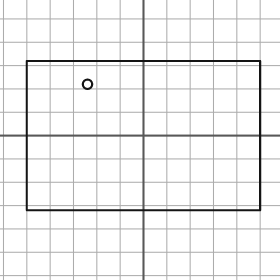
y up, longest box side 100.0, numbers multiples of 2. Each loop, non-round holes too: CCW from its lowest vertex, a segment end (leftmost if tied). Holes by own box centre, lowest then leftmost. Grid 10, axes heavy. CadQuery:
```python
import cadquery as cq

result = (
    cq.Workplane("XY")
    .moveTo(-50.0, -32.0)
    .lineTo(50.0, -32.0)
    .lineTo(50.0, 32.0)
    .lineTo(-50.0, 32.0)
    .close()
    .moveTo(-24.0, 22.0)
    .circle(2.0)
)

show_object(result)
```